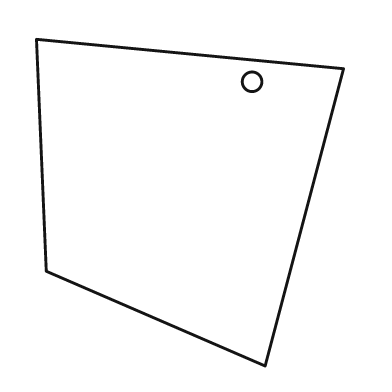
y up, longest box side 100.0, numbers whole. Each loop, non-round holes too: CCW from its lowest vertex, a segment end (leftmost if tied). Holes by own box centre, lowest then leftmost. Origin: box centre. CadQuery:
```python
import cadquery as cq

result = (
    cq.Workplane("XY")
    .moveTo(23.0, -50.0)
    .lineTo(47.0, 41.0)
    .lineTo(-47.0, 50.0)
    .lineTo(-44.0, -21.0)
    .close()
    .moveTo(19.0, 37.0)
    .circle(3.0)
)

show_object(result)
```